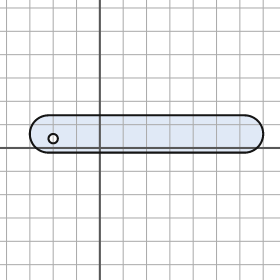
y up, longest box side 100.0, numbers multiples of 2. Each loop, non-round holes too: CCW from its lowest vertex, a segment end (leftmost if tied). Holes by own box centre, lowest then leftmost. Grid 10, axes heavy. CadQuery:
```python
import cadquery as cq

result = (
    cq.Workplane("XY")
    .moveTo(-22.0, -2.0)
    .lineTo(62.0, -2.0)
    .threePointArc((70.0, 6.0), (62.0, 14.0))
    .lineTo(-22.0, 14.0)
    .threePointArc((-30.0, 6.0), (-22.0, -2.0))
    .close()
    .moveTo(-20.0, 4.0)
    .circle(2.0)
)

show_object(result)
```